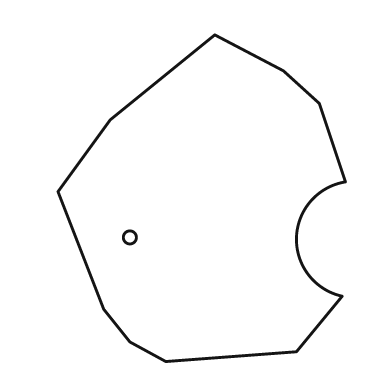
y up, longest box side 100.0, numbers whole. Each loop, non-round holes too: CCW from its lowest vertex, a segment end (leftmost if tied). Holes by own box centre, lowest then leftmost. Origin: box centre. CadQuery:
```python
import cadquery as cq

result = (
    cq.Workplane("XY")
    .moveTo(-11.0, -50.0)
    .lineTo(29.0, -47.0)
    .lineTo(43.0, -30.0)
    .threePointArc((29.0, -12.0), (44.0, 5.0))
    .lineTo(36.0, 29.0)
    .lineTo(25.0, 39.0)
    .lineTo(4.0, 50.0)
    .lineTo(-28.0, 24.0)
    .lineTo(-44.0, 2.0)
    .lineTo(-30.0, -34.0)
    .lineTo(-22.0, -44.0)
    .close()
    .moveTo(-22.0, -12.0)
    .circle(2.0)
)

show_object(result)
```